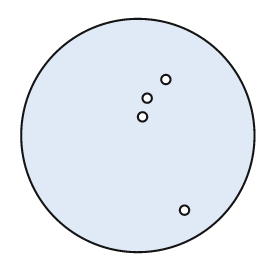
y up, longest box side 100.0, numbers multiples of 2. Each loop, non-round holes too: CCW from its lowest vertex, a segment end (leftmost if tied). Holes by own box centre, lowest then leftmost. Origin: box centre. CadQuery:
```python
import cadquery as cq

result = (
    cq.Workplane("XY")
    .moveTo(0.0, 0.0)
    .circle(50.0)
    .moveTo(20.0, -32.0)
    .circle(2.0)
    .moveTo(2.0, 8.0)
    .circle(2.0)
    .moveTo(4.0, 16.0)
    .circle(2.0)
    .moveTo(12.0, 24.0)
    .circle(2.0)
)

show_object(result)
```